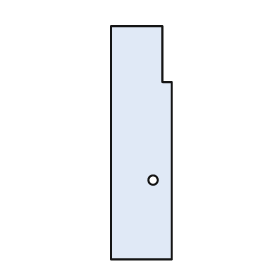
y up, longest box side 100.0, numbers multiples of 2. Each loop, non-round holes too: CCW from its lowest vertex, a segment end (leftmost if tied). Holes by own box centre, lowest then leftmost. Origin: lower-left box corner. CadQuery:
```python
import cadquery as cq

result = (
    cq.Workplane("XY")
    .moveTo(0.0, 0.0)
    .lineTo(26.0, 0.0)
    .lineTo(26.0, 76.0)
    .lineTo(22.0, 76.0)
    .lineTo(22.0, 100.0)
    .lineTo(0.0, 100.0)
    .close()
    .moveTo(18.0, 34.0)
    .circle(2.0)
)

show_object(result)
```